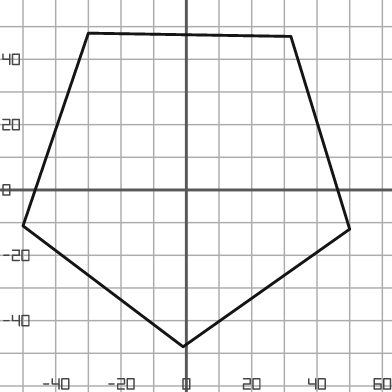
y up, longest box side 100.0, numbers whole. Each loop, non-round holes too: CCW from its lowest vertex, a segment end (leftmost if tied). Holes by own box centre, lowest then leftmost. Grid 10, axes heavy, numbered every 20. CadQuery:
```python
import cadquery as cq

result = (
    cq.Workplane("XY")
    .moveTo(-1.0, -48.0)
    .lineTo(50.0, -12.0)
    .lineTo(32.0, 47.0)
    .lineTo(-30.0, 48.0)
    .lineTo(-50.0, -11.0)
    .close()
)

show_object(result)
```